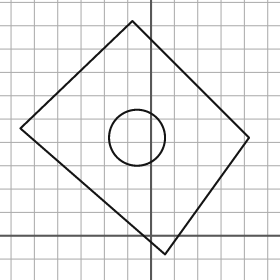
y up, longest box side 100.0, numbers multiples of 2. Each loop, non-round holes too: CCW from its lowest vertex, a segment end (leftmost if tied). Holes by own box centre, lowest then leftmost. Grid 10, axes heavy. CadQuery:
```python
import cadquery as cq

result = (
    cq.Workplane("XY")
    .moveTo(6.0, -8.0)
    .lineTo(42.0, 42.0)
    .lineTo(-8.0, 92.0)
    .lineTo(-56.0, 46.0)
    .close()
    .moveTo(-6.0, 42.0)
    .circle(12.0)
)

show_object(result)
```